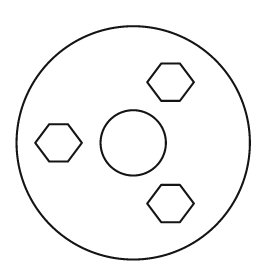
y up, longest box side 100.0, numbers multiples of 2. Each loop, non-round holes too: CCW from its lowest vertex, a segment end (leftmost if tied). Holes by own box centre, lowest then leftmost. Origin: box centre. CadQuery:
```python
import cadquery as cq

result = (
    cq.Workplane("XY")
    .moveTo(0.0, 0.0)
    .circle(50.0)
    .moveTo(12.0, -34.0)
    .lineTo(20.0, -34.0)
    .lineTo(26.0, -26.0)
    .lineTo(20.0, -18.0)
    .lineTo(12.0, -18.0)
    .lineTo(6.0, -26.0)
    .close()
    .moveTo(-36.0, -8.0)
    .lineTo(-28.0, -8.0)
    .lineTo(-22.0, 0.0)
    .lineTo(-28.0, 8.0)
    .lineTo(-36.0, 8.0)
    .lineTo(-42.0, 0.0)
    .close()
    .moveTo(0.0, 0.0)
    .circle(14.0)
    .moveTo(12.0, 18.0)
    .lineTo(20.0, 18.0)
    .lineTo(26.0, 26.0)
    .lineTo(20.0, 34.0)
    .lineTo(12.0, 34.0)
    .lineTo(6.0, 26.0)
    .close()
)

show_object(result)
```